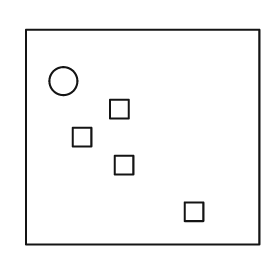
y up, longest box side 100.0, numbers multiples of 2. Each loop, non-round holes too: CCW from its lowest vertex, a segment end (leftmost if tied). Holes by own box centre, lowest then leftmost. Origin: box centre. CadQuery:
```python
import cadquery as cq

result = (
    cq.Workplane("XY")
    .moveTo(-50.0, -46.0)
    .lineTo(50.0, -46.0)
    .lineTo(50.0, 46.0)
    .lineTo(-50.0, 46.0)
    .close()
    .moveTo(18.0, -36.0)
    .lineTo(26.0, -36.0)
    .lineTo(26.0, -28.0)
    .lineTo(18.0, -28.0)
    .close()
    .moveTo(-12.0, -16.0)
    .lineTo(-4.0, -16.0)
    .lineTo(-4.0, -8.0)
    .lineTo(-12.0, -8.0)
    .close()
    .moveTo(-30.0, -4.0)
    .lineTo(-22.0, -4.0)
    .lineTo(-22.0, 4.0)
    .lineTo(-30.0, 4.0)
    .close()
    .moveTo(-14.0, 8.0)
    .lineTo(-6.0, 8.0)
    .lineTo(-6.0, 16.0)
    .lineTo(-14.0, 16.0)
    .close()
    .moveTo(-34.0, 24.0)
    .circle(6.0)
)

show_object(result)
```